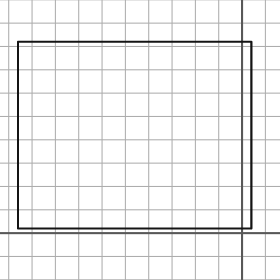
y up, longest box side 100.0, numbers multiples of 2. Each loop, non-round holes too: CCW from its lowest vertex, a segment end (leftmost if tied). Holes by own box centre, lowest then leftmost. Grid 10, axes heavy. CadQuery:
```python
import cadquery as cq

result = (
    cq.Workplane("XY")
    .moveTo(-96.0, 2.0)
    .lineTo(4.0, 2.0)
    .lineTo(4.0, 82.0)
    .lineTo(-96.0, 82.0)
    .close()
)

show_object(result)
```